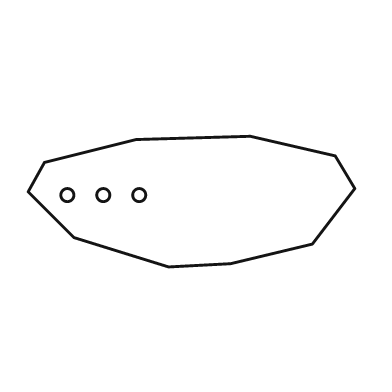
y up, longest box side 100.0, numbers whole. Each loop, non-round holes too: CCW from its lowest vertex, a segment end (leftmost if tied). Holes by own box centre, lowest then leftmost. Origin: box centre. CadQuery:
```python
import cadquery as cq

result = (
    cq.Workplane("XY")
    .moveTo(-7.0, -20.0)
    .lineTo(12.0, -19.0)
    .lineTo(37.0, -13.0)
    .lineTo(50.0, 4.0)
    .lineTo(44.0, 14.0)
    .lineTo(18.0, 20.0)
    .lineTo(-17.0, 19.0)
    .lineTo(-45.0, 12.0)
    .lineTo(-50.0, 3.0)
    .lineTo(-36.0, -11.0)
    .close()
    .moveTo(-38.0, 2.0)
    .circle(2.0)
    .moveTo(-27.0, 2.0)
    .circle(2.0)
    .moveTo(-16.0, 2.0)
    .circle(2.0)
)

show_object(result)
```